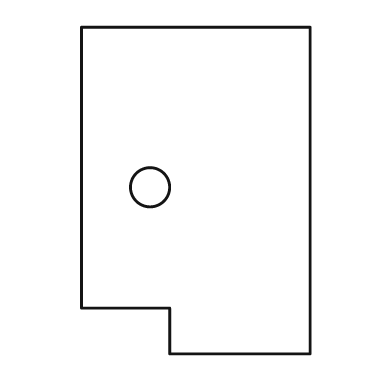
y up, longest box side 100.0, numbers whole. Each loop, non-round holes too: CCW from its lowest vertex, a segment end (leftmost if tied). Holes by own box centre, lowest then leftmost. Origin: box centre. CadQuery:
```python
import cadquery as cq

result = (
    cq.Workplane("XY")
    .moveTo(-8.0, -50.0)
    .lineTo(35.0, -50.0)
    .lineTo(35.0, 50.0)
    .lineTo(-35.0, 50.0)
    .lineTo(-35.0, -36.0)
    .lineTo(-8.0, -36.0)
    .close()
    .moveTo(-14.0, 1.0)
    .circle(6.0)
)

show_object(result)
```